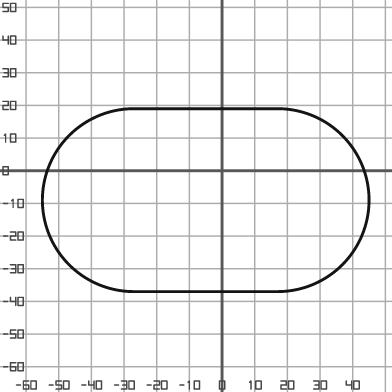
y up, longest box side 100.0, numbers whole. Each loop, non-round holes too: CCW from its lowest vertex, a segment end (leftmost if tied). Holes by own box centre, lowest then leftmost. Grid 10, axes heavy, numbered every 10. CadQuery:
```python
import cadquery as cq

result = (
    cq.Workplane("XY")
    .moveTo(-27.0, -37.0)
    .lineTo(17.0, -37.0)
    .threePointArc((45.0, -9.0), (17.0, 19.0))
    .lineTo(-27.0, 19.0)
    .threePointArc((-55.0, -9.0), (-27.0, -37.0))
    .close()
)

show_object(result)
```